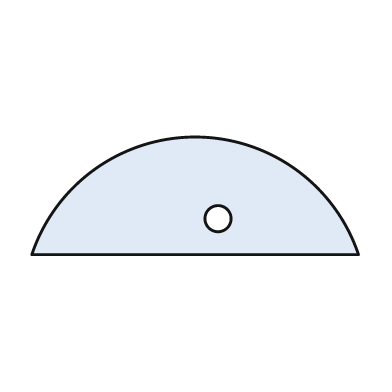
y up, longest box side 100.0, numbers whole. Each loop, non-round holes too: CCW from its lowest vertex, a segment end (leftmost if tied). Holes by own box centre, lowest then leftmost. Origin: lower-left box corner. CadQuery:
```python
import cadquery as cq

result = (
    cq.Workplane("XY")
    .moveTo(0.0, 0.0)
    .lineTo(100.0, 0.0)
    .threePointArc((50.0, 36.0), (0.0, 0.0))
    .close()
    .moveTo(57.0, 11.0)
    .circle(4.0)
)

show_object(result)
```